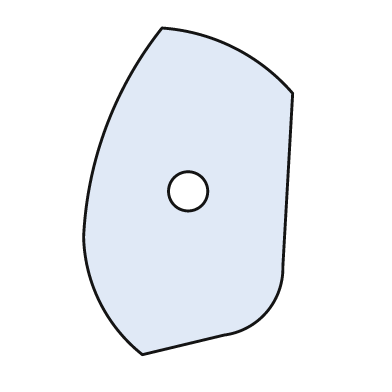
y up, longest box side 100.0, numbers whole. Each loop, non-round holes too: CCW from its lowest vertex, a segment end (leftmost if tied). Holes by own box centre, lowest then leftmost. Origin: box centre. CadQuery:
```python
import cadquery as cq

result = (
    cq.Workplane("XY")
    .moveTo(-14.0, -50.0)
    .lineTo(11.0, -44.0)
    .threePointArc((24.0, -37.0), (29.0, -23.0))
    .lineTo(32.0, 30.0)
    .threePointArc((14.0, 44.0), (-8.0, 50.0))
    .threePointArc((-25.0, 20.0), (-32.0, -14.0))
    .threePointArc((-27.0, -34.0), (-14.0, -50.0))
    .close()
    .moveTo(0.0, 0.0)
    .circle(6.0)
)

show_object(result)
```